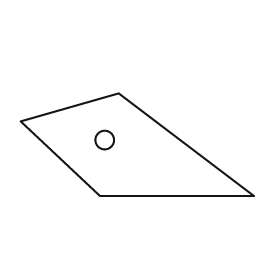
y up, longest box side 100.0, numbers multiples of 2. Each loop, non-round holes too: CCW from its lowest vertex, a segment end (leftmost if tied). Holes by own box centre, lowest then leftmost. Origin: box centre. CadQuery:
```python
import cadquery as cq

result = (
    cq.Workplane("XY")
    .moveTo(-16.0, -22.0)
    .lineTo(50.0, -22.0)
    .lineTo(-8.0, 22.0)
    .lineTo(-50.0, 10.0)
    .close()
    .moveTo(-14.0, 2.0)
    .circle(4.0)
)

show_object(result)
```